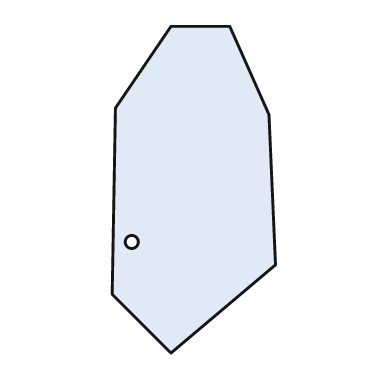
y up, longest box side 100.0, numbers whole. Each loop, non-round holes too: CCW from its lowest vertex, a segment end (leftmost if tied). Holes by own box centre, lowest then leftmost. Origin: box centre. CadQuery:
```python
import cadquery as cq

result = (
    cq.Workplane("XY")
    .moveTo(-7.0, -50.0)
    .lineTo(25.0, -23.0)
    .lineTo(23.0, 23.0)
    .lineTo(11.0, 50.0)
    .lineTo(-7.0, 50.0)
    .lineTo(-24.0, 25.0)
    .lineTo(-25.0, -32.0)
    .close()
    .moveTo(-19.0, -16.0)
    .circle(2.0)
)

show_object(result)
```